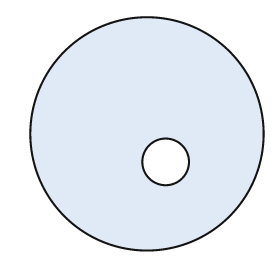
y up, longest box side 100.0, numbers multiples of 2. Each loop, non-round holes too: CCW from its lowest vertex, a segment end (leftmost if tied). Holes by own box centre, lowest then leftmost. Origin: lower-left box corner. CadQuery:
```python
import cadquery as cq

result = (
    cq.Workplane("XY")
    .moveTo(50.0, 50.0)
    .circle(50.0)
    .moveTo(58.0, 38.0)
    .circle(10.0)
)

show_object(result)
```